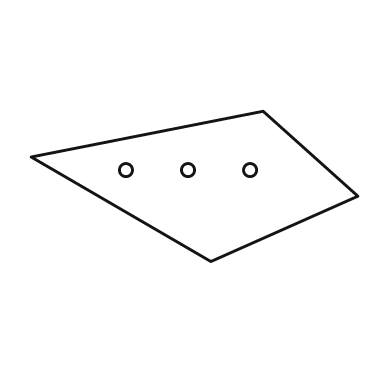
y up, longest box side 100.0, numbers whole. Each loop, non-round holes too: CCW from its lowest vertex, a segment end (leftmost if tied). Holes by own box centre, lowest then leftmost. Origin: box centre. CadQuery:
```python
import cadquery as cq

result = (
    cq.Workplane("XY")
    .moveTo(5.0, -23.0)
    .lineTo(50.0, -3.0)
    .lineTo(21.0, 23.0)
    .lineTo(-50.0, 9.0)
    .close()
    .moveTo(-21.0, 5.0)
    .circle(2.0)
    .moveTo(-2.0, 5.0)
    .circle(2.0)
    .moveTo(17.0, 5.0)
    .circle(2.0)
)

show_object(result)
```